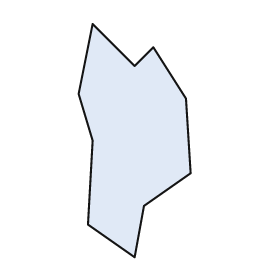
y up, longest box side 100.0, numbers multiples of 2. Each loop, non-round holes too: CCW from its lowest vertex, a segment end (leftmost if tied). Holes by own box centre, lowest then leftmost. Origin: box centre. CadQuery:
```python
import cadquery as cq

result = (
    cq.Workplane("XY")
    .moveTo(0.0, -50.0)
    .lineTo(4.0, -28.0)
    .lineTo(24.0, -14.0)
    .lineTo(22.0, 18.0)
    .lineTo(8.0, 40.0)
    .lineTo(0.0, 32.0)
    .lineTo(-18.0, 50.0)
    .lineTo(-24.0, 20.0)
    .lineTo(-18.0, 0.0)
    .lineTo(-20.0, -36.0)
    .close()
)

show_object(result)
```